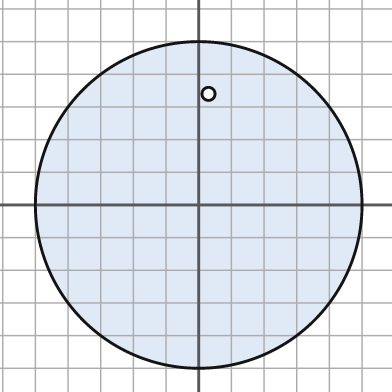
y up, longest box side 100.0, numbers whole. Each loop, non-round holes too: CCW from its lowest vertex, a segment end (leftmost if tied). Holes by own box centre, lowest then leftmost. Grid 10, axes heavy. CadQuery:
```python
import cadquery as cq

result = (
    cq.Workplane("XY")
    .moveTo(0.0, 0.0)
    .circle(50.0)
    .moveTo(3.0, 34.0)
    .circle(2.0)
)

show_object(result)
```